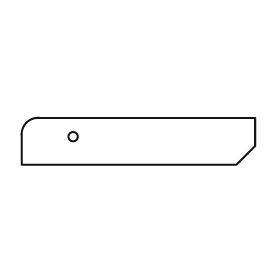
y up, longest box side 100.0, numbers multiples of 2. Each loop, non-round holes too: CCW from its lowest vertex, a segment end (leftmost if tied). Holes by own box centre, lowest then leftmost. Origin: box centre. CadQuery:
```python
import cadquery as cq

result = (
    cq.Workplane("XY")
    .moveTo(-50.0, -10.0)
    .lineTo(42.0, -10.0)
    .lineTo(50.0, -2.0)
    .lineTo(50.0, 10.0)
    .lineTo(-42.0, 10.0)
    .threePointArc((-48.0, 8.0), (-50.0, 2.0))
    .close()
    .moveTo(-28.0, 2.0)
    .circle(2.0)
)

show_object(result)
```